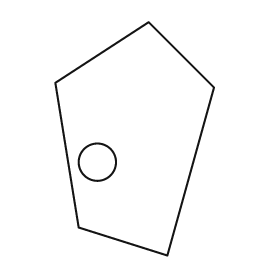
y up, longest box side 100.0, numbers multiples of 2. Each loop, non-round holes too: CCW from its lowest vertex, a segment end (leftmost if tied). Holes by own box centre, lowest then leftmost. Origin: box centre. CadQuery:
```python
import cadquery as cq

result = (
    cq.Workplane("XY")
    .moveTo(14.0, -50.0)
    .lineTo(34.0, 22.0)
    .lineTo(6.0, 50.0)
    .lineTo(-34.0, 24.0)
    .lineTo(-24.0, -38.0)
    .close()
    .moveTo(-16.0, -10.0)
    .circle(8.0)
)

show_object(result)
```